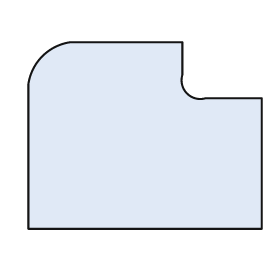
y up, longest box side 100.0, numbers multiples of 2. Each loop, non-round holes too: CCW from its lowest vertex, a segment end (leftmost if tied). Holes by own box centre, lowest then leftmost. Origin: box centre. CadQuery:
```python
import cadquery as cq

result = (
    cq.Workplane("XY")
    .moveTo(-50.0, -40.0)
    .lineTo(50.0, -40.0)
    .lineTo(50.0, 16.0)
    .lineTo(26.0, 16.0)
    .threePointArc((18.0, 18.0), (16.0, 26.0))
    .lineTo(16.0, 40.0)
    .lineTo(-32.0, 40.0)
    .threePointArc((-44.0, 34.0), (-50.0, 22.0))
    .close()
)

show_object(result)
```